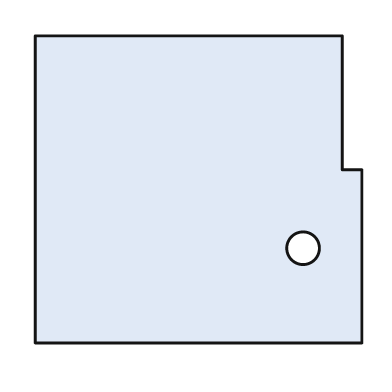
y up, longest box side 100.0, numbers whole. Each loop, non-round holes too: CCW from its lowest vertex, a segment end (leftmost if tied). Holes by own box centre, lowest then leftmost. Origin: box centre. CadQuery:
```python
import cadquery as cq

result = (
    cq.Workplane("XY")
    .moveTo(-50.0, -47.0)
    .lineTo(50.0, -47.0)
    .lineTo(50.0, 6.0)
    .lineTo(44.0, 6.0)
    .lineTo(44.0, 47.0)
    .lineTo(-50.0, 47.0)
    .close()
    .moveTo(32.0, -18.0)
    .circle(5.0)
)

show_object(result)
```